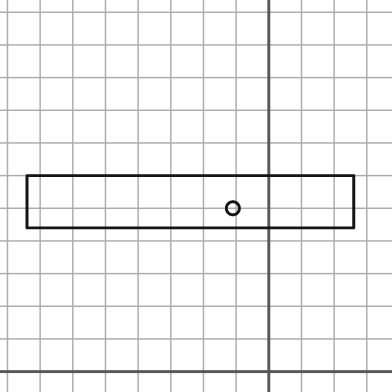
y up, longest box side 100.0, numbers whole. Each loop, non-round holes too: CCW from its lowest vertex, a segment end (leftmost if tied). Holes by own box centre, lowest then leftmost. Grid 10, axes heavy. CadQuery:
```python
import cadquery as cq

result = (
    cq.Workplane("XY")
    .moveTo(-74.0, 44.0)
    .lineTo(26.0, 44.0)
    .lineTo(26.0, 60.0)
    .lineTo(-74.0, 60.0)
    .close()
    .moveTo(-11.0, 50.0)
    .circle(2.0)
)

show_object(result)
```